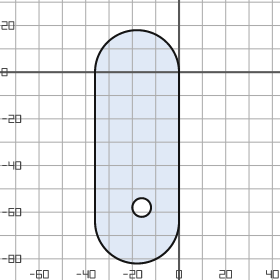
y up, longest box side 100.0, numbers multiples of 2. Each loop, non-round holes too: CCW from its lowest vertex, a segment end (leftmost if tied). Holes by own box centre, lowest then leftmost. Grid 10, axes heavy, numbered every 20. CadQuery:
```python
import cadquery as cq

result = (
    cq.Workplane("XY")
    .moveTo(-36.0, -64.0)
    .threePointArc((-18.0, -82.0), (0.0, -64.0))
    .lineTo(0.0, 0.0)
    .threePointArc((-18.0, 18.0), (-36.0, 0.0))
    .close()
    .moveTo(-16.0, -58.0)
    .circle(4.0)
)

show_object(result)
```